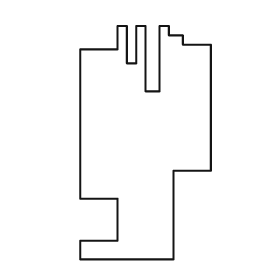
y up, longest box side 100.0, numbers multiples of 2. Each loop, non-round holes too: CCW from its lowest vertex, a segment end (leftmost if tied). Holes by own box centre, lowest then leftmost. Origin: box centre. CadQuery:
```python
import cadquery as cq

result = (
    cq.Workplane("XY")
    .moveTo(-28.0, -50.0)
    .lineTo(12.0, -50.0)
    .lineTo(12.0, -12.0)
    .lineTo(28.0, -12.0)
    .lineTo(28.0, 42.0)
    .lineTo(16.0, 42.0)
    .lineTo(16.0, 46.0)
    .lineTo(10.0, 46.0)
    .lineTo(10.0, 50.0)
    .lineTo(6.0, 50.0)
    .lineTo(6.0, 22.0)
    .lineTo(0.0, 22.0)
    .lineTo(0.0, 50.0)
    .lineTo(-4.0, 50.0)
    .lineTo(-4.0, 34.0)
    .lineTo(-8.0, 34.0)
    .lineTo(-8.0, 50.0)
    .lineTo(-12.0, 50.0)
    .lineTo(-12.0, 40.0)
    .lineTo(-28.0, 40.0)
    .lineTo(-28.0, -24.0)
    .lineTo(-12.0, -24.0)
    .lineTo(-12.0, -42.0)
    .lineTo(-28.0, -42.0)
    .close()
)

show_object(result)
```